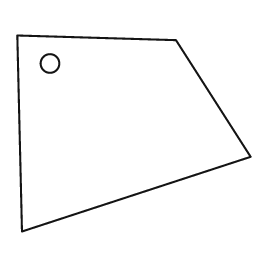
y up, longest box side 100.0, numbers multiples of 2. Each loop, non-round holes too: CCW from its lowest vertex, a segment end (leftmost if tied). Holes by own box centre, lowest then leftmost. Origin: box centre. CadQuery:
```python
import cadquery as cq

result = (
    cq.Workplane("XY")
    .moveTo(-48.0, -42.0)
    .lineTo(50.0, -10.0)
    .lineTo(18.0, 40.0)
    .lineTo(-50.0, 42.0)
    .close()
    .moveTo(-36.0, 30.0)
    .circle(4.0)
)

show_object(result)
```